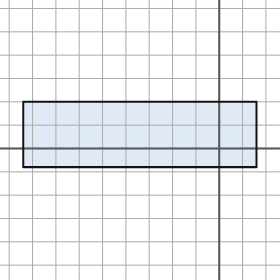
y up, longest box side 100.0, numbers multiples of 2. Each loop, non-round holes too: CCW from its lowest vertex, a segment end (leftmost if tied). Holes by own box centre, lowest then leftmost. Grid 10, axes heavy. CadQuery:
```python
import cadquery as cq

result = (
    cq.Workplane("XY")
    .moveTo(-84.0, -8.0)
    .lineTo(16.0, -8.0)
    .lineTo(16.0, 20.0)
    .lineTo(-84.0, 20.0)
    .close()
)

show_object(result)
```